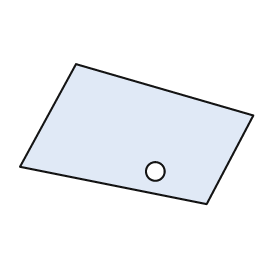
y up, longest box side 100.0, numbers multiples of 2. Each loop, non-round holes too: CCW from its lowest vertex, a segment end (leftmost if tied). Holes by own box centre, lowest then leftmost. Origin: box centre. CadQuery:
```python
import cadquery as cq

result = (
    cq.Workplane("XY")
    .moveTo(30.0, -30.0)
    .lineTo(50.0, 8.0)
    .lineTo(-26.0, 30.0)
    .lineTo(-50.0, -14.0)
    .close()
    .moveTo(8.0, -16.0)
    .circle(4.0)
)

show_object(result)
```